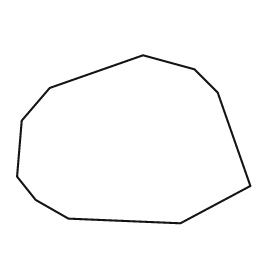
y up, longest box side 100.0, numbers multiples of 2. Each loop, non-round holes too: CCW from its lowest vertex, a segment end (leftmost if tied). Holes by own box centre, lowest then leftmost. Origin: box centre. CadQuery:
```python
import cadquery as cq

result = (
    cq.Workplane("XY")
    .moveTo(20.0, -36.0)
    .lineTo(50.0, -20.0)
    .lineTo(36.0, 20.0)
    .lineTo(26.0, 30.0)
    .lineTo(4.0, 36.0)
    .lineTo(-36.0, 22.0)
    .lineTo(-48.0, 8.0)
    .lineTo(-50.0, -16.0)
    .lineTo(-42.0, -26.0)
    .lineTo(-28.0, -34.0)
    .close()
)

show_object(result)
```